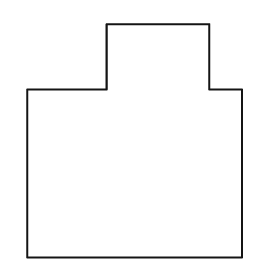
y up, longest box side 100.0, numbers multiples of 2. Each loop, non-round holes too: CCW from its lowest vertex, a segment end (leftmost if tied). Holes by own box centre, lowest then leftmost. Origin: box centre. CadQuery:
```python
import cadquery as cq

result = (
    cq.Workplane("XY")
    .moveTo(-46.0, -50.0)
    .lineTo(46.0, -50.0)
    .lineTo(46.0, 22.0)
    .lineTo(32.0, 22.0)
    .lineTo(32.0, 50.0)
    .lineTo(-12.0, 50.0)
    .lineTo(-12.0, 22.0)
    .lineTo(-46.0, 22.0)
    .close()
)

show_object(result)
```